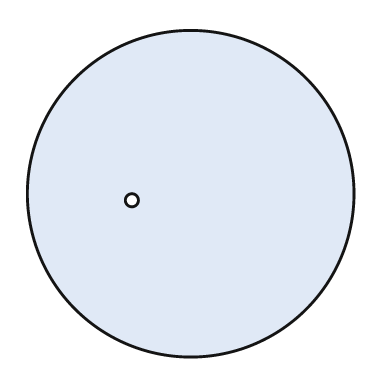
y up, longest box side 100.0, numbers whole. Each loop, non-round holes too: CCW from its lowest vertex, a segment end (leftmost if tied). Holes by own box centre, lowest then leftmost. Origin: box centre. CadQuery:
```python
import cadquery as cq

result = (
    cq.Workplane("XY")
    .moveTo(0.0, 0.0)
    .circle(50.0)
    .moveTo(-18.0, -2.0)
    .circle(2.0)
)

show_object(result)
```